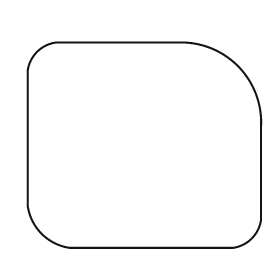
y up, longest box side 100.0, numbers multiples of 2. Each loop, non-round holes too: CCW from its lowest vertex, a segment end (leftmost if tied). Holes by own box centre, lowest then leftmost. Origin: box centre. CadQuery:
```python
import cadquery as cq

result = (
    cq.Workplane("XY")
    .moveTo(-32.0, -44.0)
    .lineTo(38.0, -44.0)
    .threePointArc((46.0, -40.0), (50.0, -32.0))
    .lineTo(50.0, 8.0)
    .threePointArc((40.0, 34.0), (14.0, 44.0))
    .lineTo(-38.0, 44.0)
    .threePointArc((-46.0, 40.0), (-50.0, 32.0))
    .lineTo(-50.0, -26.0)
    .threePointArc((-44.0, -38.0), (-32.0, -44.0))
    .close()
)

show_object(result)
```